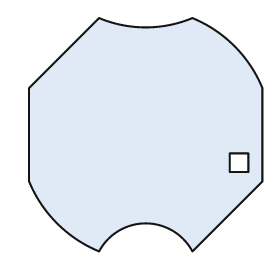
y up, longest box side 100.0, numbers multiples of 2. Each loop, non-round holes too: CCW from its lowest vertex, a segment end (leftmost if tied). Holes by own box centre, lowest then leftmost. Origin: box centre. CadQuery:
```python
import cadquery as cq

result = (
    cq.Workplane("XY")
    .moveTo(-20.0, -50.0)
    .threePointArc((0.0, -38.0), (20.0, -50.0))
    .lineTo(50.0, -20.0)
    .lineTo(50.0, 20.0)
    .threePointArc((38.0, 38.0), (20.0, 50.0))
    .threePointArc((0.0, 46.0), (-20.0, 50.0))
    .lineTo(-50.0, 20.0)
    .lineTo(-50.0, -20.0)
    .threePointArc((-38.0, -38.0), (-20.0, -50.0))
    .close()
    .moveTo(36.0, -16.0)
    .lineTo(44.0, -16.0)
    .lineTo(44.0, -8.0)
    .lineTo(36.0, -8.0)
    .close()
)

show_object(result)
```